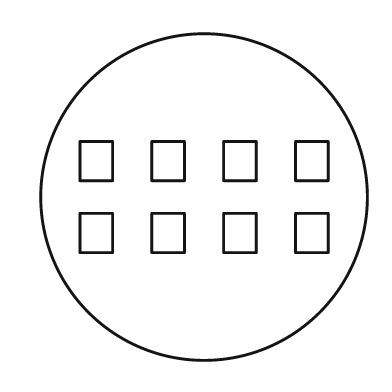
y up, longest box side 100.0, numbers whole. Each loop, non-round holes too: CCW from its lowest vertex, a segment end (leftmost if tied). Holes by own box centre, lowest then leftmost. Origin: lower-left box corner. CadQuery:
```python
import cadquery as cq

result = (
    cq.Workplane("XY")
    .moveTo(50.0, 50.0)
    .circle(50.0)
    .moveTo(12.0, 33.0)
    .lineTo(22.0, 33.0)
    .lineTo(22.0, 45.0)
    .lineTo(12.0, 45.0)
    .close()
    .moveTo(34.0, 33.0)
    .lineTo(44.0, 33.0)
    .lineTo(44.0, 45.0)
    .lineTo(34.0, 45.0)
    .close()
    .moveTo(56.0, 33.0)
    .lineTo(66.0, 33.0)
    .lineTo(66.0, 45.0)
    .lineTo(56.0, 45.0)
    .close()
    .moveTo(78.0, 33.0)
    .lineTo(88.0, 33.0)
    .lineTo(88.0, 45.0)
    .lineTo(78.0, 45.0)
    .close()
    .moveTo(12.0, 55.0)
    .lineTo(22.0, 55.0)
    .lineTo(22.0, 67.0)
    .lineTo(12.0, 67.0)
    .close()
    .moveTo(34.0, 55.0)
    .lineTo(44.0, 55.0)
    .lineTo(44.0, 67.0)
    .lineTo(34.0, 67.0)
    .close()
    .moveTo(56.0, 55.0)
    .lineTo(66.0, 55.0)
    .lineTo(66.0, 67.0)
    .lineTo(56.0, 67.0)
    .close()
    .moveTo(78.0, 55.0)
    .lineTo(88.0, 55.0)
    .lineTo(88.0, 67.0)
    .lineTo(78.0, 67.0)
    .close()
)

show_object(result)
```